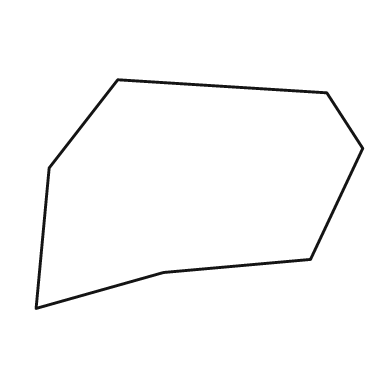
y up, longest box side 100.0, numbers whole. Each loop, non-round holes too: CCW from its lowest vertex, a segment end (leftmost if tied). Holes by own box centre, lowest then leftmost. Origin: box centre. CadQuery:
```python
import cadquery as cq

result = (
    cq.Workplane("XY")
    .moveTo(-50.0, -35.0)
    .lineTo(-11.0, -24.0)
    .lineTo(34.0, -20.0)
    .lineTo(50.0, 14.0)
    .lineTo(39.0, 31.0)
    .lineTo(-25.0, 35.0)
    .lineTo(-46.0, 8.0)
    .close()
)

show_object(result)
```